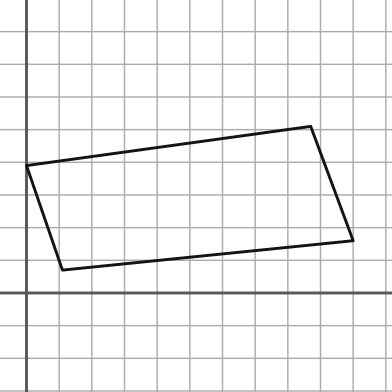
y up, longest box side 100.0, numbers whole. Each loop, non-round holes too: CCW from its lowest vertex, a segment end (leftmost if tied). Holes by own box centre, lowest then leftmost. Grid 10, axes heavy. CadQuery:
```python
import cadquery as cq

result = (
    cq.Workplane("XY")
    .moveTo(11.0, 7.0)
    .lineTo(100.0, 16.0)
    .lineTo(87.0, 51.0)
    .lineTo(0.0, 39.0)
    .close()
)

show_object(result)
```